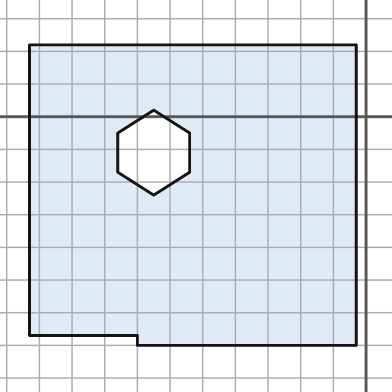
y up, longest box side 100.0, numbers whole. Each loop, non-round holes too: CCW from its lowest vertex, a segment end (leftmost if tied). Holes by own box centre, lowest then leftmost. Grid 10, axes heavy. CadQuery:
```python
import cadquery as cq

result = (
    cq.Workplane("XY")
    .moveTo(-70.0, -70.0)
    .lineTo(-3.0, -70.0)
    .lineTo(-3.0, 22.0)
    .lineTo(-103.0, 22.0)
    .lineTo(-103.0, -67.0)
    .lineTo(-70.0, -67.0)
    .close()
    .moveTo(-65.0, -24.0)
    .lineTo(-54.0, -17.0)
    .lineTo(-54.0, -5.0)
    .lineTo(-65.0, 2.0)
    .lineTo(-76.0, -5.0)
    .lineTo(-76.0, -17.0)
    .close()
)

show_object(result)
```